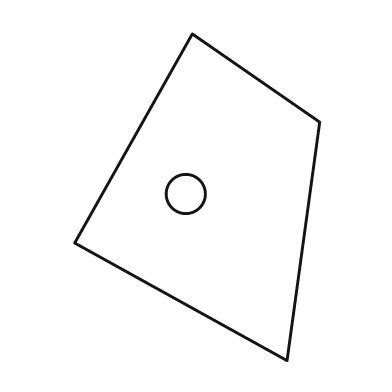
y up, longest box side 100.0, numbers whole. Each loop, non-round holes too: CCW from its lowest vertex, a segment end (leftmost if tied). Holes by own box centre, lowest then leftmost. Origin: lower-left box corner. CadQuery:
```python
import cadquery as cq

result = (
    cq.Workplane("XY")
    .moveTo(65.0, 0.0)
    .lineTo(75.0, 73.0)
    .lineTo(36.0, 100.0)
    .lineTo(0.0, 36.0)
    .close()
    .moveTo(34.0, 51.0)
    .circle(6.0)
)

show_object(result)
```